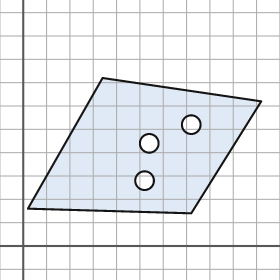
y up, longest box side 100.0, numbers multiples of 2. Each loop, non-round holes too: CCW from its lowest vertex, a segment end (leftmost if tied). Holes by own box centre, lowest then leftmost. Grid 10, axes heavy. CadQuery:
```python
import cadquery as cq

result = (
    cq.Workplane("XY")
    .moveTo(72.0, 14.0)
    .lineTo(102.0, 62.0)
    .lineTo(34.0, 72.0)
    .lineTo(2.0, 16.0)
    .close()
    .moveTo(52.0, 28.0)
    .circle(4.0)
    .moveTo(54.0, 44.0)
    .circle(4.0)
    .moveTo(72.0, 52.0)
    .circle(4.0)
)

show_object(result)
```